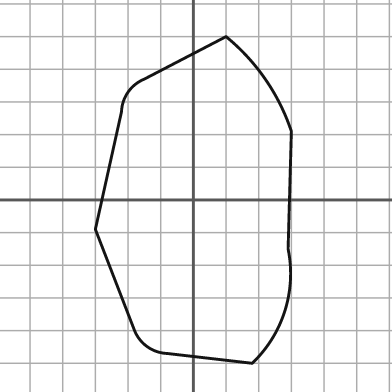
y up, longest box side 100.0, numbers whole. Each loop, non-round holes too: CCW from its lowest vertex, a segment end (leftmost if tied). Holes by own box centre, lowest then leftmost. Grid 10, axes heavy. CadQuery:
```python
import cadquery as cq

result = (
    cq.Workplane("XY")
    .moveTo(18.0, -50.0)
    .threePointArc((28.0, -34.0), (29.0, -15.0))
    .lineTo(30.0, 21.0)
    .threePointArc((22.0, 37.0), (10.0, 50.0))
    .lineTo(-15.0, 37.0)
    .threePointArc((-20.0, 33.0), (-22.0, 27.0))
    .lineTo(-30.0, -9.0)
    .lineTo(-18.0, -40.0)
    .threePointArc((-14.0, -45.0), (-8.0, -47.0))
    .close()
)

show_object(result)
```